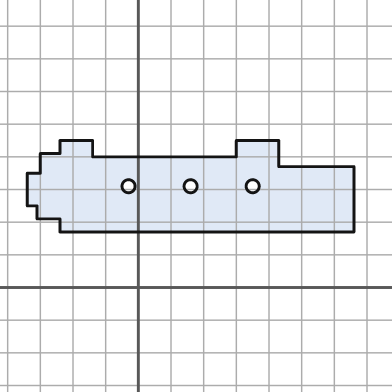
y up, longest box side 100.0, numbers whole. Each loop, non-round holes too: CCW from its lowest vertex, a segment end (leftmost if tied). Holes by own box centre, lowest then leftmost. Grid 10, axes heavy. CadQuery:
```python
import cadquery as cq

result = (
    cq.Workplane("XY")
    .moveTo(-24.0, 17.0)
    .lineTo(66.0, 17.0)
    .lineTo(66.0, 37.0)
    .lineTo(43.0, 37.0)
    .lineTo(43.0, 45.0)
    .lineTo(30.0, 45.0)
    .lineTo(30.0, 40.0)
    .lineTo(-14.0, 40.0)
    .lineTo(-14.0, 45.0)
    .lineTo(-24.0, 45.0)
    .lineTo(-24.0, 41.0)
    .lineTo(-30.0, 41.0)
    .lineTo(-30.0, 35.0)
    .lineTo(-34.0, 35.0)
    .lineTo(-34.0, 25.0)
    .lineTo(-31.0, 25.0)
    .lineTo(-31.0, 21.0)
    .lineTo(-24.0, 21.0)
    .close()
    .moveTo(-3.0, 31.0)
    .circle(2.0)
    .moveTo(16.0, 31.0)
    .circle(2.0)
    .moveTo(35.0, 31.0)
    .circle(2.0)
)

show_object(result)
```